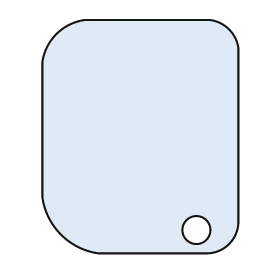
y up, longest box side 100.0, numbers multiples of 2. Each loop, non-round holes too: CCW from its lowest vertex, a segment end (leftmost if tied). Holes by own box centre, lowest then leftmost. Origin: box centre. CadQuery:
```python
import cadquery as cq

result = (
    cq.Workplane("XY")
    .moveTo(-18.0, -50.0)
    .lineTo(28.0, -50.0)
    .threePointArc((38.0, -46.0), (42.0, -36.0))
    .lineTo(42.0, 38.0)
    .threePointArc((38.0, 46.0), (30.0, 50.0))
    .lineTo(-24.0, 50.0)
    .threePointArc((-36.0, 44.0), (-42.0, 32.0))
    .lineTo(-42.0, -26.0)
    .threePointArc((-34.0, -42.0), (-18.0, -50.0))
    .close()
    .moveTo(24.0, -40.0)
    .circle(6.0)
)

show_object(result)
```